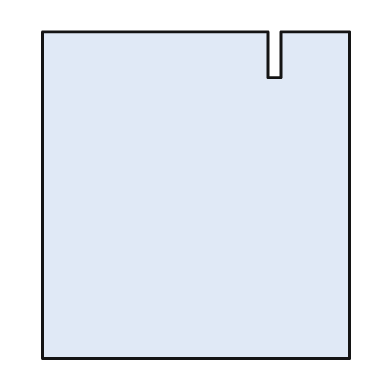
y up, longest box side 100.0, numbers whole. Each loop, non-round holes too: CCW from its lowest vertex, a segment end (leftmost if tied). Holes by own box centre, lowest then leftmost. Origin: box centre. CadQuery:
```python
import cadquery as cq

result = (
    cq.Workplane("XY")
    .moveTo(-47.0, -50.0)
    .lineTo(47.0, -50.0)
    .lineTo(47.0, 50.0)
    .lineTo(26.0, 50.0)
    .lineTo(26.0, 36.0)
    .lineTo(22.0, 36.0)
    .lineTo(22.0, 50.0)
    .lineTo(-47.0, 50.0)
    .close()
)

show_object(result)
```